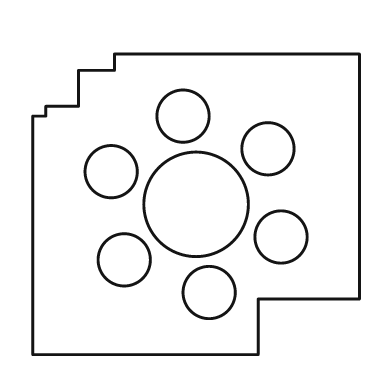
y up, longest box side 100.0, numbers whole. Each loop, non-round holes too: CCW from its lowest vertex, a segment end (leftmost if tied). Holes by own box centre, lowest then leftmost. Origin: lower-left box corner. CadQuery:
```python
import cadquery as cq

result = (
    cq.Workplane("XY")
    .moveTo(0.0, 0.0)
    .lineTo(69.0, 0.0)
    .lineTo(69.0, 17.0)
    .lineTo(100.0, 17.0)
    .lineTo(100.0, 92.0)
    .lineTo(25.0, 92.0)
    .lineTo(25.0, 87.0)
    .lineTo(14.0, 87.0)
    .lineTo(14.0, 76.0)
    .lineTo(4.0, 76.0)
    .lineTo(4.0, 73.0)
    .lineTo(0.0, 73.0)
    .close()
    .moveTo(54.0, 19.0)
    .circle(8.0)
    .moveTo(28.0, 29.0)
    .circle(8.0)
    .moveTo(76.0, 36.0)
    .circle(8.0)
    .moveTo(50.0, 46.0)
    .circle(16.0)
    .moveTo(24.0, 56.0)
    .circle(8.0)
    .moveTo(72.0, 63.0)
    .circle(8.0)
    .moveTo(46.0, 73.0)
    .circle(8.0)
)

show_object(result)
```